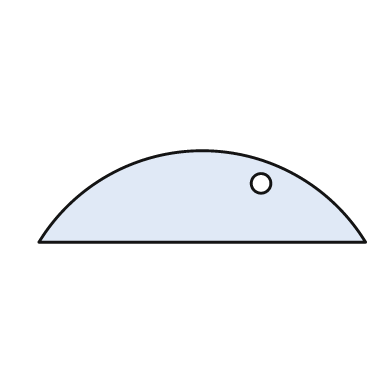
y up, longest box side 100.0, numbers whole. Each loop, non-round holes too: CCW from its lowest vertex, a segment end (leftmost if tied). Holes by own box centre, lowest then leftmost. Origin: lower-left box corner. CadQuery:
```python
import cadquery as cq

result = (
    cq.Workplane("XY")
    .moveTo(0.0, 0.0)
    .lineTo(100.0, 0.0)
    .threePointArc((50.0, 28.0), (0.0, 0.0))
    .close()
    .moveTo(68.0, 18.0)
    .circle(3.0)
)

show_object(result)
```